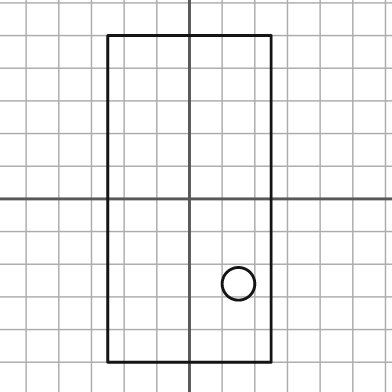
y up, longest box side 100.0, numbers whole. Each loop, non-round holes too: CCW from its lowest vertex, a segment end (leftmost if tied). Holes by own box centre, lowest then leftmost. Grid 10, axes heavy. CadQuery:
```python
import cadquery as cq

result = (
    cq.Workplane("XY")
    .moveTo(-25.0, -50.0)
    .lineTo(25.0, -50.0)
    .lineTo(25.0, 50.0)
    .lineTo(-25.0, 50.0)
    .close()
    .moveTo(15.0, -26.0)
    .circle(5.0)
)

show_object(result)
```